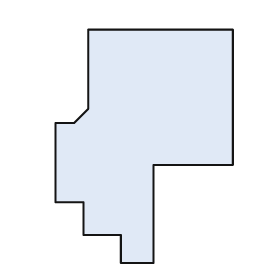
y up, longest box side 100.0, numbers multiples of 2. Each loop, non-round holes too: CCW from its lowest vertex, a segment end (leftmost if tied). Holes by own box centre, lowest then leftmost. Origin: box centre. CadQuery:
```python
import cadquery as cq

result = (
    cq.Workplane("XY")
    .moveTo(-10.0, -50.0)
    .lineTo(4.0, -50.0)
    .lineTo(4.0, -8.0)
    .lineTo(38.0, -8.0)
    .lineTo(38.0, 50.0)
    .lineTo(-24.0, 50.0)
    .lineTo(-24.0, 16.0)
    .lineTo(-30.0, 10.0)
    .lineTo(-38.0, 10.0)
    .lineTo(-38.0, -24.0)
    .lineTo(-26.0, -24.0)
    .lineTo(-26.0, -38.0)
    .lineTo(-10.0, -38.0)
    .close()
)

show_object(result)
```